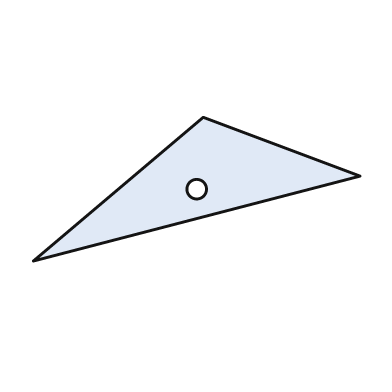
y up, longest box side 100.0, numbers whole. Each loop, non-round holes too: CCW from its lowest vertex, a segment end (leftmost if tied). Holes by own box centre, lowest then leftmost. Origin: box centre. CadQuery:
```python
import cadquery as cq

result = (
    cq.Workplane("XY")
    .moveTo(-50.0, -22.0)
    .lineTo(50.0, 4.0)
    .lineTo(2.0, 22.0)
    .close()
    .moveTo(0.0, 0.0)
    .circle(3.0)
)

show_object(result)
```